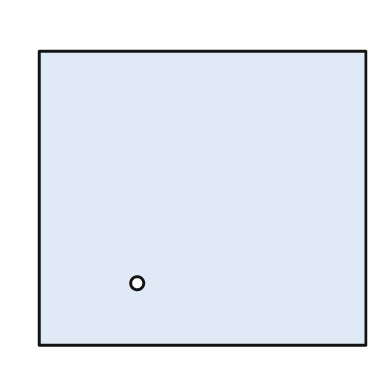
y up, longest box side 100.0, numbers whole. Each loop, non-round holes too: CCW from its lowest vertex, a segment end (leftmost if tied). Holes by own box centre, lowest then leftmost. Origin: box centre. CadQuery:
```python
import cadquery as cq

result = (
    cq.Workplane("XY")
    .moveTo(-50.0, -45.0)
    .lineTo(50.0, -45.0)
    .lineTo(50.0, 45.0)
    .lineTo(-50.0, 45.0)
    .close()
    .moveTo(-20.0, -26.0)
    .circle(2.0)
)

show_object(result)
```